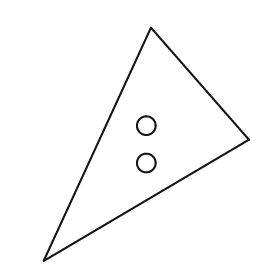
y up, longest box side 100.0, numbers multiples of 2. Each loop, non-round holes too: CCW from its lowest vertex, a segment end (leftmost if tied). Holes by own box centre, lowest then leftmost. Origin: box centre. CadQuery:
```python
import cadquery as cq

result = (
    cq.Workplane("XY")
    .moveTo(-44.0, -50.0)
    .lineTo(44.0, 2.0)
    .lineTo(2.0, 50.0)
    .close()
    .moveTo(0.0, -8.0)
    .circle(4.0)
    .moveTo(0.0, 8.0)
    .circle(4.0)
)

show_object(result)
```